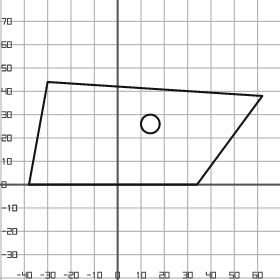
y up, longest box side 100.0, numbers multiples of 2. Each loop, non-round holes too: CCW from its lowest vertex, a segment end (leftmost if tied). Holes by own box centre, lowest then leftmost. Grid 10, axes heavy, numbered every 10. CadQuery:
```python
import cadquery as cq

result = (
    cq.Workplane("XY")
    .moveTo(-38.0, 0.0)
    .lineTo(34.0, 0.0)
    .lineTo(62.0, 38.0)
    .lineTo(-30.0, 44.0)
    .close()
    .moveTo(14.0, 26.0)
    .circle(4.0)
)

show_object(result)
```